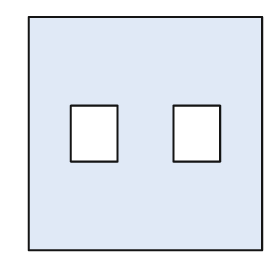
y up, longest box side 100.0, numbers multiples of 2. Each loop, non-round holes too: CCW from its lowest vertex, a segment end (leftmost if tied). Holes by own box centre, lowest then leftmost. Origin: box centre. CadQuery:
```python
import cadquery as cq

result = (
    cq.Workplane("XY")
    .moveTo(-50.0, -50.0)
    .lineTo(50.0, -50.0)
    .lineTo(50.0, 50.0)
    .lineTo(-50.0, 50.0)
    .close()
    .moveTo(-32.0, -12.0)
    .lineTo(-12.0, -12.0)
    .lineTo(-12.0, 12.0)
    .lineTo(-32.0, 12.0)
    .close()
    .moveTo(12.0, -12.0)
    .lineTo(32.0, -12.0)
    .lineTo(32.0, 12.0)
    .lineTo(12.0, 12.0)
    .close()
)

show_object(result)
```